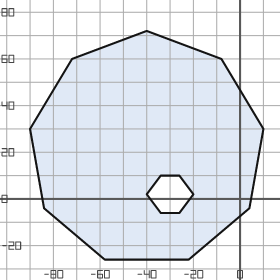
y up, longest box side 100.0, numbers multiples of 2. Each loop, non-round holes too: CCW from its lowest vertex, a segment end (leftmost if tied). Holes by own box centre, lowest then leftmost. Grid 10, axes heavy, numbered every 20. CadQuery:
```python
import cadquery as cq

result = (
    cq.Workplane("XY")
    .moveTo(-58.0, -26.0)
    .lineTo(-22.0, -26.0)
    .lineTo(4.0, -4.0)
    .lineTo(10.0, 30.0)
    .lineTo(-8.0, 60.0)
    .lineTo(-40.0, 72.0)
    .lineTo(-72.0, 60.0)
    .lineTo(-90.0, 30.0)
    .lineTo(-84.0, -4.0)
    .close()
    .moveTo(-34.0, -6.0)
    .lineTo(-26.0, -6.0)
    .lineTo(-20.0, 2.0)
    .lineTo(-26.0, 10.0)
    .lineTo(-34.0, 10.0)
    .lineTo(-40.0, 2.0)
    .close()
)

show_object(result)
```